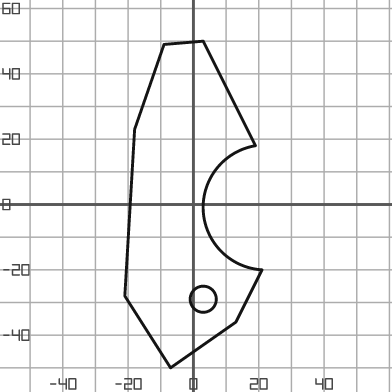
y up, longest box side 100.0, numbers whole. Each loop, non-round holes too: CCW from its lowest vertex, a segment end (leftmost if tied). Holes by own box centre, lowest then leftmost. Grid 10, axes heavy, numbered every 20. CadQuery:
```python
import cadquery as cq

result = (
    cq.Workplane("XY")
    .moveTo(-7.0, -50.0)
    .lineTo(13.0, -36.0)
    .lineTo(21.0, -20.0)
    .threePointArc((3.0, -2.0), (19.0, 18.0))
    .lineTo(3.0, 50.0)
    .lineTo(-9.0, 49.0)
    .lineTo(-18.0, 23.0)
    .lineTo(-21.0, -28.0)
    .close()
    .moveTo(3.0, -29.0)
    .circle(4.0)
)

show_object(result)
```